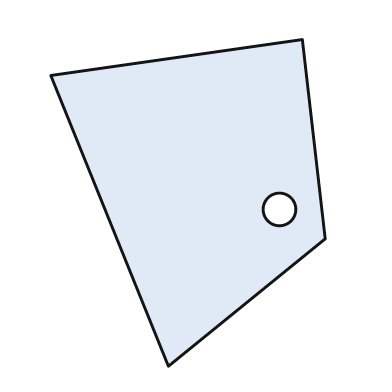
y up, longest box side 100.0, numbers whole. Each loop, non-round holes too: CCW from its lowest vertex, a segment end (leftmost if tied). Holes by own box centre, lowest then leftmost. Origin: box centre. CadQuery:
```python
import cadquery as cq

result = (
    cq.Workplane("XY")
    .moveTo(-6.0, -50.0)
    .lineTo(42.0, -11.0)
    .lineTo(35.0, 50.0)
    .lineTo(-42.0, 39.0)
    .close()
    .moveTo(28.0, -2.0)
    .circle(5.0)
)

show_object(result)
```